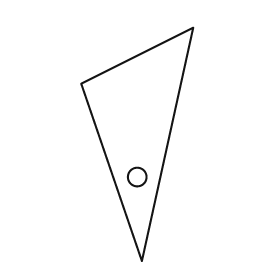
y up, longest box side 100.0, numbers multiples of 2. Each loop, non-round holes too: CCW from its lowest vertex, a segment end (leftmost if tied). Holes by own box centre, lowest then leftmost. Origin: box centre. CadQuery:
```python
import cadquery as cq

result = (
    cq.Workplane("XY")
    .moveTo(2.0, -50.0)
    .lineTo(24.0, 50.0)
    .lineTo(-24.0, 26.0)
    .close()
    .moveTo(0.0, -14.0)
    .circle(4.0)
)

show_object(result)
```